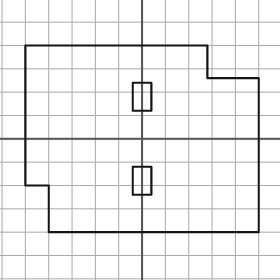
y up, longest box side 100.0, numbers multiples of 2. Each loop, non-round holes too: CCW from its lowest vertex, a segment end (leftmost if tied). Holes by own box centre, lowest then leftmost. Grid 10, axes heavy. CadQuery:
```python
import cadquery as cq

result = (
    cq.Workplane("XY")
    .moveTo(-40.0, -40.0)
    .lineTo(50.0, -40.0)
    .lineTo(50.0, 26.0)
    .lineTo(28.0, 26.0)
    .lineTo(28.0, 40.0)
    .lineTo(-50.0, 40.0)
    .lineTo(-50.0, -20.0)
    .lineTo(-40.0, -20.0)
    .close()
    .moveTo(-4.0, -24.0)
    .lineTo(4.0, -24.0)
    .lineTo(4.0, -12.0)
    .lineTo(-4.0, -12.0)
    .close()
    .moveTo(-4.0, 12.0)
    .lineTo(4.0, 12.0)
    .lineTo(4.0, 24.0)
    .lineTo(-4.0, 24.0)
    .close()
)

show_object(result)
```